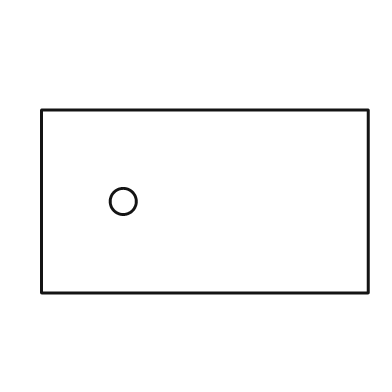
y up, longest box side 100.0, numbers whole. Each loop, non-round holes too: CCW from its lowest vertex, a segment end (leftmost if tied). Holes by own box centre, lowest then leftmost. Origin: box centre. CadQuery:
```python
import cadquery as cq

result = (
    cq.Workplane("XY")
    .moveTo(-50.0, -28.0)
    .lineTo(50.0, -28.0)
    .lineTo(50.0, 28.0)
    .lineTo(-50.0, 28.0)
    .close()
    .moveTo(-25.0, 0.0)
    .circle(4.0)
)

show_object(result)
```